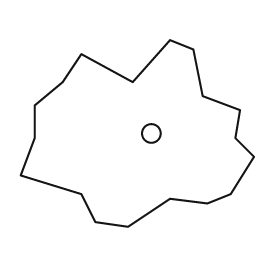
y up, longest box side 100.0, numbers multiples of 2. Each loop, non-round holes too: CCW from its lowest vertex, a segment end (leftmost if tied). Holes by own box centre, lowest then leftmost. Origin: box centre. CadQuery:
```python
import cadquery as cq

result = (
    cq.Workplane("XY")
    .moveTo(-4.0, -40.0)
    .lineTo(14.0, -28.0)
    .lineTo(30.0, -30.0)
    .lineTo(40.0, -26.0)
    .lineTo(50.0, -10.0)
    .lineTo(42.0, -2.0)
    .lineTo(44.0, 10.0)
    .lineTo(28.0, 16.0)
    .lineTo(24.0, 36.0)
    .lineTo(14.0, 40.0)
    .lineTo(-2.0, 22.0)
    .lineTo(-24.0, 34.0)
    .lineTo(-32.0, 22.0)
    .lineTo(-44.0, 12.0)
    .lineTo(-44.0, -2.0)
    .lineTo(-50.0, -18.0)
    .lineTo(-24.0, -26.0)
    .lineTo(-18.0, -38.0)
    .close()
    .moveTo(6.0, 0.0)
    .circle(4.0)
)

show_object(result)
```